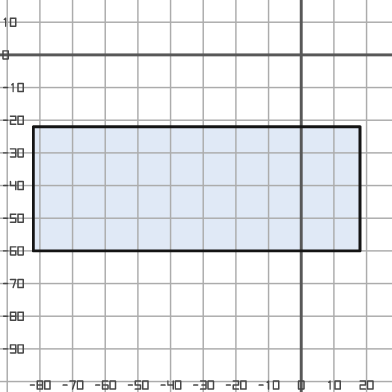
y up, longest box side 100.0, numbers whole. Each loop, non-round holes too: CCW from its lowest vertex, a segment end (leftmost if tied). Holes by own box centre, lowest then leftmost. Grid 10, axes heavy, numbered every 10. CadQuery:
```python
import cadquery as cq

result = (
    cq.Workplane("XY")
    .moveTo(-82.0, -60.0)
    .lineTo(18.0, -60.0)
    .lineTo(18.0, -22.0)
    .lineTo(-82.0, -22.0)
    .close()
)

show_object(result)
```